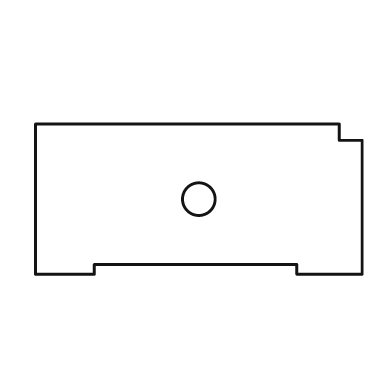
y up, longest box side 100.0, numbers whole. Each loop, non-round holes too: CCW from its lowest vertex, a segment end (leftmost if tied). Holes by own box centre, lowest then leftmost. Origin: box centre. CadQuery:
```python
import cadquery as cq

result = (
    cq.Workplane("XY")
    .moveTo(-50.0, -23.0)
    .lineTo(-32.0, -23.0)
    .lineTo(-32.0, -20.0)
    .lineTo(30.0, -20.0)
    .lineTo(30.0, -23.0)
    .lineTo(50.0, -23.0)
    .lineTo(50.0, 18.0)
    .lineTo(43.0, 18.0)
    .lineTo(43.0, 23.0)
    .lineTo(-50.0, 23.0)
    .close()
    .moveTo(0.0, 0.0)
    .circle(5.0)
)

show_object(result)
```